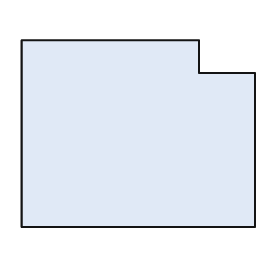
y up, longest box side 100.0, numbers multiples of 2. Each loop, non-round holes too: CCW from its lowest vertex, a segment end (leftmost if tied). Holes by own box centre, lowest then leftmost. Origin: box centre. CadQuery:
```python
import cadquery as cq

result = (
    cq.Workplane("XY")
    .moveTo(-50.0, -40.0)
    .lineTo(50.0, -40.0)
    .lineTo(50.0, 26.0)
    .lineTo(26.0, 26.0)
    .lineTo(26.0, 40.0)
    .lineTo(-50.0, 40.0)
    .close()
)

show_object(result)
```